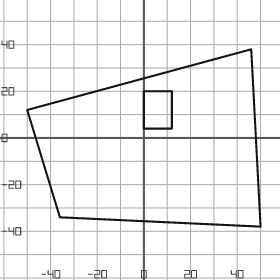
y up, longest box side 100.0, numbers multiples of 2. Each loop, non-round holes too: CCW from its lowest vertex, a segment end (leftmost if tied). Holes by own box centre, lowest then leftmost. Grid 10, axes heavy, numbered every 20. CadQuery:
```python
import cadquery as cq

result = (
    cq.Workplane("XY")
    .moveTo(50.0, -38.0)
    .lineTo(46.0, 38.0)
    .lineTo(-50.0, 12.0)
    .lineTo(-36.0, -34.0)
    .close()
    .moveTo(0.0, 4.0)
    .lineTo(12.0, 4.0)
    .lineTo(12.0, 20.0)
    .lineTo(0.0, 20.0)
    .close()
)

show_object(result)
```